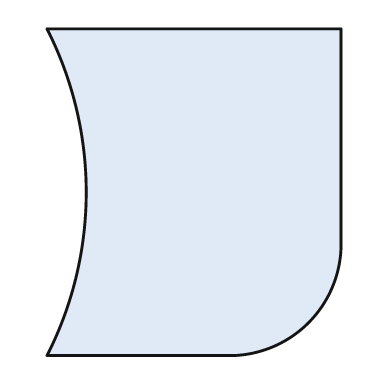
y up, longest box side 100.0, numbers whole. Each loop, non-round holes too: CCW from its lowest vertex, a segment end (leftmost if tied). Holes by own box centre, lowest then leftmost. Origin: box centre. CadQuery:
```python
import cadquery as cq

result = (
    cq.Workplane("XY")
    .moveTo(-45.0, -50.0)
    .lineTo(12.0, -50.0)
    .threePointArc((35.0, -40.0), (45.0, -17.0))
    .lineTo(45.0, 50.0)
    .lineTo(-45.0, 50.0)
    .threePointArc((-33.0, 0.0), (-45.0, -50.0))
    .close()
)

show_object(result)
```